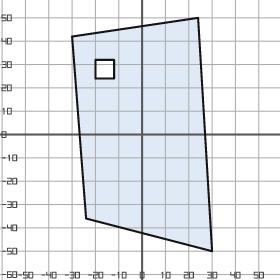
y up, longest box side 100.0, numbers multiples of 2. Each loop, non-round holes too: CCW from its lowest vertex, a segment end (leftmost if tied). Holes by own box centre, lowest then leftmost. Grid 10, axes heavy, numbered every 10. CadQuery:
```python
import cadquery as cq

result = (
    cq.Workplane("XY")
    .moveTo(30.0, -50.0)
    .lineTo(24.0, 50.0)
    .lineTo(-30.0, 42.0)
    .lineTo(-24.0, -36.0)
    .close()
    .moveTo(-20.0, 24.0)
    .lineTo(-12.0, 24.0)
    .lineTo(-12.0, 32.0)
    .lineTo(-20.0, 32.0)
    .close()
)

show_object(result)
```